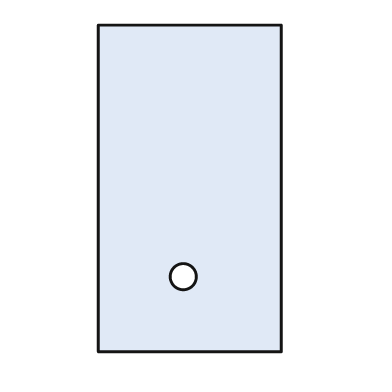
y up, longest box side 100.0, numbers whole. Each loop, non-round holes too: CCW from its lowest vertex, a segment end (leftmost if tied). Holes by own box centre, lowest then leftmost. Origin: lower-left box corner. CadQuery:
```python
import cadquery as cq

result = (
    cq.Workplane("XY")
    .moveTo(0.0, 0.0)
    .lineTo(56.0, 0.0)
    .lineTo(56.0, 100.0)
    .lineTo(0.0, 100.0)
    .close()
    .moveTo(26.0, 23.0)
    .circle(4.0)
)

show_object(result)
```